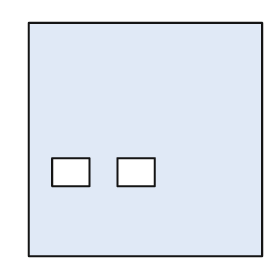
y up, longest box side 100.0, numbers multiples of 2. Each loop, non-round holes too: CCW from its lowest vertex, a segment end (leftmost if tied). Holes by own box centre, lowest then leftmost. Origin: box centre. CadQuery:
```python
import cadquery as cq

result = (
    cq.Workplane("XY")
    .moveTo(-50.0, -50.0)
    .lineTo(50.0, -50.0)
    .lineTo(50.0, 50.0)
    .lineTo(-50.0, 50.0)
    .close()
    .moveTo(-40.0, -20.0)
    .lineTo(-24.0, -20.0)
    .lineTo(-24.0, -8.0)
    .lineTo(-40.0, -8.0)
    .close()
    .moveTo(-12.0, -20.0)
    .lineTo(4.0, -20.0)
    .lineTo(4.0, -8.0)
    .lineTo(-12.0, -8.0)
    .close()
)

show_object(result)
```